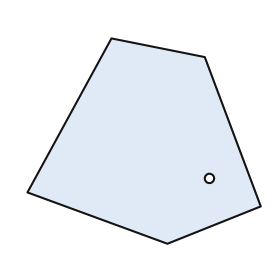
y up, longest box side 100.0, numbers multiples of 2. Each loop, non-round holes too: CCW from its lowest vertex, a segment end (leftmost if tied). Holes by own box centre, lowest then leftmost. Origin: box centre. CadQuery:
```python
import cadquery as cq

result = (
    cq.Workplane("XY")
    .moveTo(10.0, -44.0)
    .lineTo(50.0, -28.0)
    .lineTo(26.0, 36.0)
    .lineTo(-14.0, 44.0)
    .lineTo(-50.0, -22.0)
    .close()
    .moveTo(28.0, -16.0)
    .circle(2.0)
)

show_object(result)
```